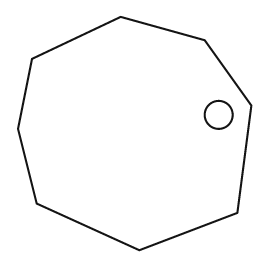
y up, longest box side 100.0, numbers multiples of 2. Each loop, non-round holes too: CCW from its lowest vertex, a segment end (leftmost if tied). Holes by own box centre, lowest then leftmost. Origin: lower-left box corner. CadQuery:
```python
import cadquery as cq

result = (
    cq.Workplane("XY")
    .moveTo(52.0, 0.0)
    .lineTo(94.0, 16.0)
    .lineTo(100.0, 62.0)
    .lineTo(80.0, 90.0)
    .lineTo(44.0, 100.0)
    .lineTo(6.0, 82.0)
    .lineTo(0.0, 52.0)
    .lineTo(8.0, 20.0)
    .close()
    .moveTo(86.0, 58.0)
    .circle(6.0)
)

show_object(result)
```